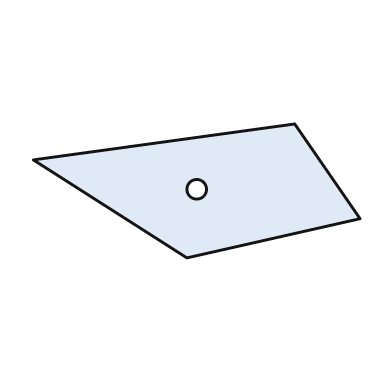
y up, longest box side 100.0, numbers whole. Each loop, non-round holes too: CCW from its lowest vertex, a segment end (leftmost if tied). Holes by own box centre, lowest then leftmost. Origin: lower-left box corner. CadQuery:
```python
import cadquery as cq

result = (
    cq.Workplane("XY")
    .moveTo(47.0, 0.0)
    .lineTo(100.0, 12.0)
    .lineTo(80.0, 41.0)
    .lineTo(0.0, 30.0)
    .close()
    .moveTo(50.0, 21.0)
    .circle(3.0)
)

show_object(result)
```